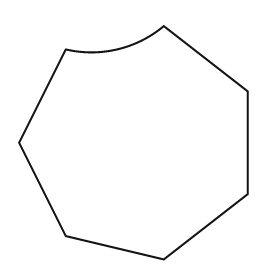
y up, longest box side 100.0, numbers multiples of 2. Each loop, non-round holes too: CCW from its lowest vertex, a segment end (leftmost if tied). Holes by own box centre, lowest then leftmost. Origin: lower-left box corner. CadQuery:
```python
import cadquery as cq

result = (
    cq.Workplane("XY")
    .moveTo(62.0, 0.0)
    .lineTo(98.0, 28.0)
    .lineTo(98.0, 72.0)
    .lineTo(62.0, 100.0)
    .threePointArc((42.0, 90.0), (20.0, 90.0))
    .lineTo(0.0, 50.0)
    .lineTo(20.0, 10.0)
    .close()
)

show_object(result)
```